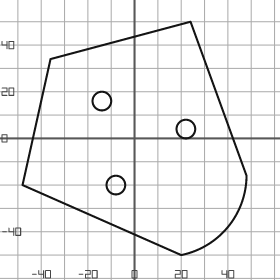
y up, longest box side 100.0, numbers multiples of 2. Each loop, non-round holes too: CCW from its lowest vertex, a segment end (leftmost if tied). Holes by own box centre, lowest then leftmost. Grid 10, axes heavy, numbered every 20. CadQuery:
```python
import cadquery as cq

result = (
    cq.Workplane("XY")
    .moveTo(20.0, -50.0)
    .threePointArc((40.0, -38.0), (48.0, -16.0))
    .lineTo(24.0, 50.0)
    .lineTo(-36.0, 34.0)
    .lineTo(-48.0, -20.0)
    .close()
    .moveTo(-8.0, -20.0)
    .circle(4.0)
    .moveTo(22.0, 4.0)
    .circle(4.0)
    .moveTo(-14.0, 16.0)
    .circle(4.0)
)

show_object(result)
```